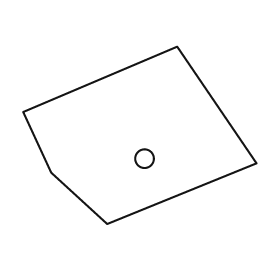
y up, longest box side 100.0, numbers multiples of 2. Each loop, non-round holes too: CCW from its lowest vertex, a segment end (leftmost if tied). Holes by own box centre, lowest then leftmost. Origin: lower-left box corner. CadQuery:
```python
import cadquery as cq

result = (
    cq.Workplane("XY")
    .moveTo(36.0, 0.0)
    .lineTo(100.0, 26.0)
    .lineTo(66.0, 76.0)
    .lineTo(0.0, 48.0)
    .lineTo(12.0, 22.0)
    .close()
    .moveTo(52.0, 28.0)
    .circle(4.0)
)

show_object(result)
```